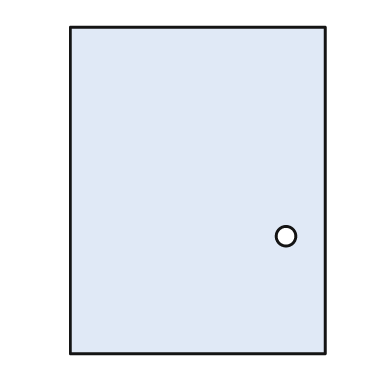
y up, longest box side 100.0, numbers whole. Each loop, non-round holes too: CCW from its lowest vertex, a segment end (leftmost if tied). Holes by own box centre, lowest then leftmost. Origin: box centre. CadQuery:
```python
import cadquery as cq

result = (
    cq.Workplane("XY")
    .moveTo(-39.0, -50.0)
    .lineTo(39.0, -50.0)
    .lineTo(39.0, 50.0)
    .lineTo(-39.0, 50.0)
    .close()
    .moveTo(27.0, -14.0)
    .circle(3.0)
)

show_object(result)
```